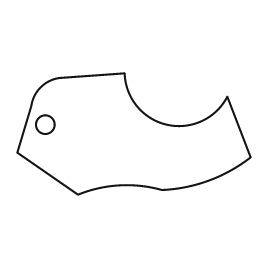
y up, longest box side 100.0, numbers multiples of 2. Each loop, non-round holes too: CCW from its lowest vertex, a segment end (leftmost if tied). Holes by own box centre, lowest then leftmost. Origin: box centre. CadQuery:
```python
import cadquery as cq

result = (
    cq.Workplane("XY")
    .moveTo(-24.0, -26.0)
    .threePointArc((-6.0, -22.0), (12.0, -24.0))
    .threePointArc((32.0, -20.0), (50.0, -10.0))
    .lineTo(40.0, 16.0)
    .threePointArc((14.0, 4.0), (-4.0, 26.0))
    .lineTo(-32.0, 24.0)
    .threePointArc((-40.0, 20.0), (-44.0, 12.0))
    .lineTo(-50.0, -8.0)
    .close()
    .moveTo(-38.0, 4.0)
    .circle(4.0)
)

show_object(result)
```